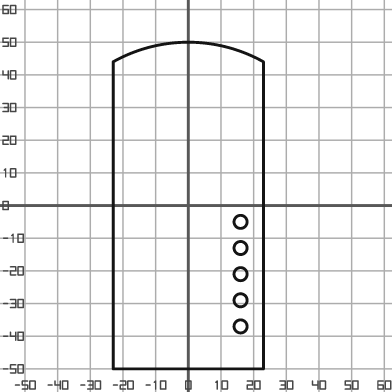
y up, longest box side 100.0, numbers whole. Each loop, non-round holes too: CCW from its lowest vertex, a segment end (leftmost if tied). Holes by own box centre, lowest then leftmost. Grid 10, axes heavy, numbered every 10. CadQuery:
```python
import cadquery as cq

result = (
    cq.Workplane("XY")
    .moveTo(-23.0, -50.0)
    .lineTo(23.0, -50.0)
    .lineTo(23.0, 44.0)
    .threePointArc((0.0, 50.0), (-23.0, 44.0))
    .close()
    .moveTo(16.0, -37.0)
    .circle(2.0)
    .moveTo(16.0, -29.0)
    .circle(2.0)
    .moveTo(16.0, -21.0)
    .circle(2.0)
    .moveTo(16.0, -13.0)
    .circle(2.0)
    .moveTo(16.0, -5.0)
    .circle(2.0)
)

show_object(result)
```